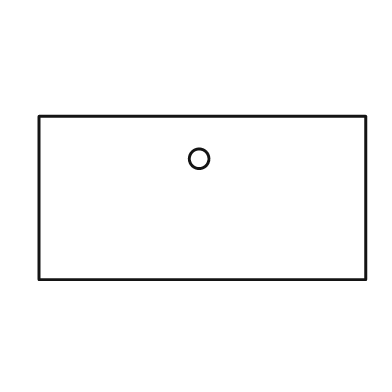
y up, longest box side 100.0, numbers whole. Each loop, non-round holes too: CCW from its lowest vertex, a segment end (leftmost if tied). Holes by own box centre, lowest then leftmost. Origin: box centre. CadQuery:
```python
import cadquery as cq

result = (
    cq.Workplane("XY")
    .moveTo(-50.0, -25.0)
    .lineTo(50.0, -25.0)
    .lineTo(50.0, 25.0)
    .lineTo(-50.0, 25.0)
    .close()
    .moveTo(-1.0, 12.0)
    .circle(3.0)
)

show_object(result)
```